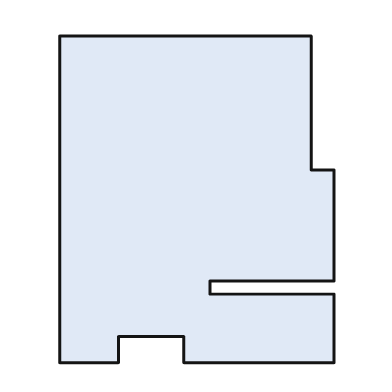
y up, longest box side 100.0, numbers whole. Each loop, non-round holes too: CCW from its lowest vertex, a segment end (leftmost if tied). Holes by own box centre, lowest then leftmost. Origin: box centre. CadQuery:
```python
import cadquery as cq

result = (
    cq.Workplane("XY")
    .moveTo(-42.0, -50.0)
    .lineTo(-24.0, -50.0)
    .lineTo(-24.0, -42.0)
    .lineTo(-4.0, -42.0)
    .lineTo(-4.0, -50.0)
    .lineTo(42.0, -50.0)
    .lineTo(42.0, -29.0)
    .lineTo(4.0, -29.0)
    .lineTo(4.0, -25.0)
    .lineTo(42.0, -25.0)
    .lineTo(42.0, 9.0)
    .lineTo(35.0, 9.0)
    .lineTo(35.0, 50.0)
    .lineTo(-42.0, 50.0)
    .close()
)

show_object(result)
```